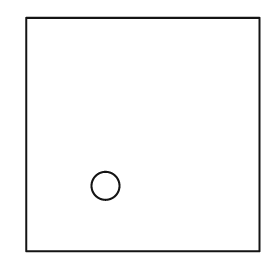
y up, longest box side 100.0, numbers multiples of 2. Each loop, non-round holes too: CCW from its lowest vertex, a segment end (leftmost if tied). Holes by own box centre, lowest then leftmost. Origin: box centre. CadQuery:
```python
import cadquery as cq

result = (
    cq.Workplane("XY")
    .moveTo(-50.0, -50.0)
    .lineTo(50.0, -50.0)
    .lineTo(50.0, 50.0)
    .lineTo(-50.0, 50.0)
    .close()
    .moveTo(-16.0, -22.0)
    .circle(6.0)
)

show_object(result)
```